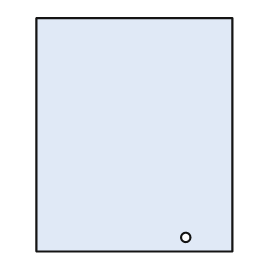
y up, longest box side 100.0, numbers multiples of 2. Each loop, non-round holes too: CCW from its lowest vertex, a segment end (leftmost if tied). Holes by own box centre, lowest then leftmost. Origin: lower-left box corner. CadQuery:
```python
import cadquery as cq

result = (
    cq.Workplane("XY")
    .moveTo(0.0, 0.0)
    .lineTo(84.0, 0.0)
    .lineTo(84.0, 100.0)
    .lineTo(0.0, 100.0)
    .close()
    .moveTo(64.0, 6.0)
    .circle(2.0)
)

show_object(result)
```